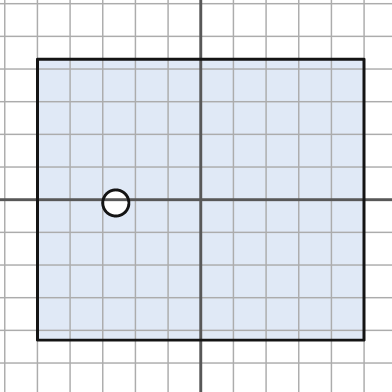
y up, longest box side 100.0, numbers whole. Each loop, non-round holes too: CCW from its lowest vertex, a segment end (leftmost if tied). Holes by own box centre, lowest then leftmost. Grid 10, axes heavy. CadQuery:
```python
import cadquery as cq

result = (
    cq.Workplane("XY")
    .moveTo(-50.0, -43.0)
    .lineTo(50.0, -43.0)
    .lineTo(50.0, 43.0)
    .lineTo(-50.0, 43.0)
    .close()
    .moveTo(-26.0, -1.0)
    .circle(4.0)
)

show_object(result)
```